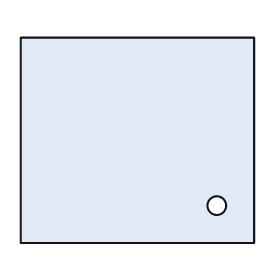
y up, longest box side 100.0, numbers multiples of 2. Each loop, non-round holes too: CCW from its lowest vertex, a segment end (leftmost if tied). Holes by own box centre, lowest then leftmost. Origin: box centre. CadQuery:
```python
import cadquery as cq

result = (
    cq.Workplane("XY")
    .moveTo(-50.0, -44.0)
    .lineTo(50.0, -44.0)
    .lineTo(50.0, 44.0)
    .lineTo(-50.0, 44.0)
    .close()
    .moveTo(34.0, -28.0)
    .circle(4.0)
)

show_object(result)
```